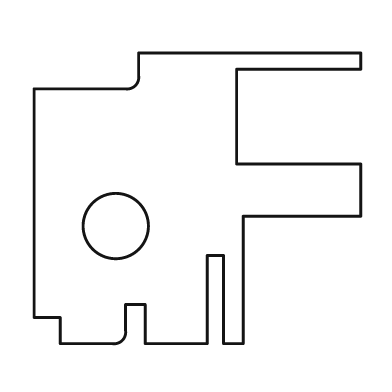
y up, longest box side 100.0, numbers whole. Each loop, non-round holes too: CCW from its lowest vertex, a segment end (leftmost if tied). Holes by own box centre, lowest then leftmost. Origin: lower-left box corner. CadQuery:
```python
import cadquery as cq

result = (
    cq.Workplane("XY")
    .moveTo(8.0, 0.0)
    .lineTo(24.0, 0.0)
    .threePointArc((27.0, 1.0), (28.0, 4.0))
    .lineTo(28.0, 12.0)
    .lineTo(34.0, 12.0)
    .lineTo(34.0, 0.0)
    .lineTo(53.0, 0.0)
    .lineTo(53.0, 27.0)
    .lineTo(58.0, 27.0)
    .lineTo(58.0, 0.0)
    .lineTo(64.0, 0.0)
    .lineTo(64.0, 39.0)
    .lineTo(100.0, 39.0)
    .lineTo(100.0, 55.0)
    .lineTo(62.0, 55.0)
    .lineTo(62.0, 84.0)
    .lineTo(100.0, 84.0)
    .lineTo(100.0, 89.0)
    .lineTo(32.0, 89.0)
    .lineTo(32.0, 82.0)
    .threePointArc((31.0, 79.0), (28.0, 78.0))
    .lineTo(0.0, 78.0)
    .lineTo(0.0, 8.0)
    .lineTo(8.0, 8.0)
    .close()
    .moveTo(25.0, 36.0)
    .circle(10.0)
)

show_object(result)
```